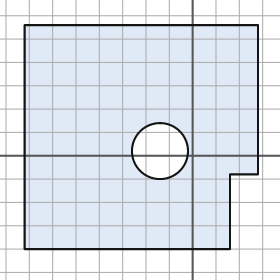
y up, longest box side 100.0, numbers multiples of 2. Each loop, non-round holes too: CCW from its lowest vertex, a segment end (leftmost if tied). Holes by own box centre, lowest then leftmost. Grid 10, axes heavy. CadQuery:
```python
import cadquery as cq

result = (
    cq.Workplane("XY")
    .moveTo(-72.0, -40.0)
    .lineTo(16.0, -40.0)
    .lineTo(16.0, -8.0)
    .lineTo(28.0, -8.0)
    .lineTo(28.0, 56.0)
    .lineTo(-72.0, 56.0)
    .close()
    .moveTo(-14.0, 2.0)
    .circle(12.0)
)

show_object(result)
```